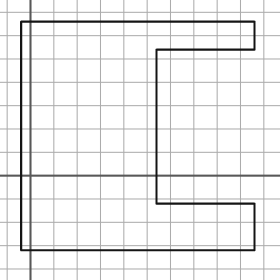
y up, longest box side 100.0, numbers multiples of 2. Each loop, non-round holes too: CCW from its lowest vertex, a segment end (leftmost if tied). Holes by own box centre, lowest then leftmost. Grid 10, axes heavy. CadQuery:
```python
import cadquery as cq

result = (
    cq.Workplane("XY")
    .moveTo(-4.0, -32.0)
    .lineTo(96.0, -32.0)
    .lineTo(96.0, -12.0)
    .lineTo(54.0, -12.0)
    .lineTo(54.0, 54.0)
    .lineTo(96.0, 54.0)
    .lineTo(96.0, 66.0)
    .lineTo(-4.0, 66.0)
    .close()
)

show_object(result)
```